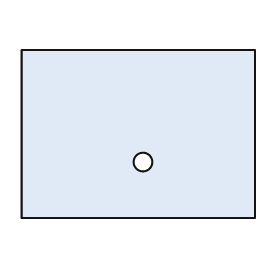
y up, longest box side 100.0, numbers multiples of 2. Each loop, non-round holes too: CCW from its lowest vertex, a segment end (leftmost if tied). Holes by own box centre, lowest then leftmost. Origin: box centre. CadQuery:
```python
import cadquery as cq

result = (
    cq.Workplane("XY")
    .moveTo(-50.0, -36.0)
    .lineTo(50.0, -36.0)
    .lineTo(50.0, 36.0)
    .lineTo(-50.0, 36.0)
    .close()
    .moveTo(2.0, -12.0)
    .circle(4.0)
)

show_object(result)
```